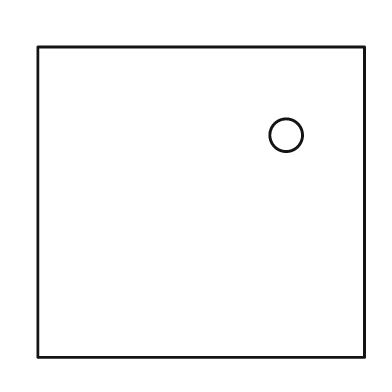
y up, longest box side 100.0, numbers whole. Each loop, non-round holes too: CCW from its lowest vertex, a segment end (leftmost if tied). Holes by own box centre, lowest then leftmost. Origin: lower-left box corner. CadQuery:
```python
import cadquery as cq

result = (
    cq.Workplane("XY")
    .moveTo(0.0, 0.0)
    .lineTo(100.0, 0.0)
    .lineTo(100.0, 95.0)
    .lineTo(0.0, 95.0)
    .close()
    .moveTo(76.0, 68.0)
    .circle(5.0)
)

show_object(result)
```